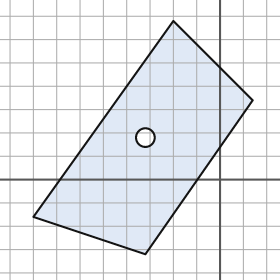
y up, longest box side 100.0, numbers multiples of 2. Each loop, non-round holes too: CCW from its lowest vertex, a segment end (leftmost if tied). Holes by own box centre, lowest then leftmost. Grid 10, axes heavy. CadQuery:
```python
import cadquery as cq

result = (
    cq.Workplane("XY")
    .moveTo(-32.0, -32.0)
    .lineTo(14.0, 34.0)
    .lineTo(-20.0, 68.0)
    .lineTo(-80.0, -16.0)
    .close()
    .moveTo(-32.0, 18.0)
    .circle(4.0)
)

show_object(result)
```